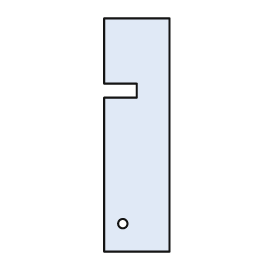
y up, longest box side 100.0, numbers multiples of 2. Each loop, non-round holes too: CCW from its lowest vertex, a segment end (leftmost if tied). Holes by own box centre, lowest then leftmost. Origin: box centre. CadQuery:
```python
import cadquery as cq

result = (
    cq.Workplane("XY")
    .moveTo(-14.0, -50.0)
    .lineTo(14.0, -50.0)
    .lineTo(14.0, 50.0)
    .lineTo(-14.0, 50.0)
    .lineTo(-14.0, 22.0)
    .lineTo(0.0, 22.0)
    .lineTo(0.0, 16.0)
    .lineTo(-14.0, 16.0)
    .close()
    .moveTo(-6.0, -38.0)
    .circle(2.0)
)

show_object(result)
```